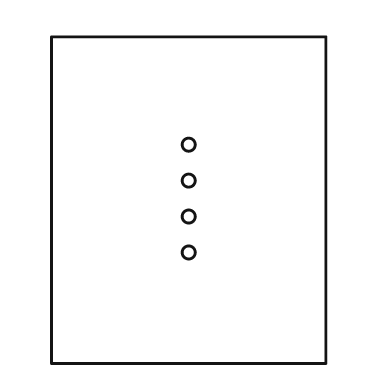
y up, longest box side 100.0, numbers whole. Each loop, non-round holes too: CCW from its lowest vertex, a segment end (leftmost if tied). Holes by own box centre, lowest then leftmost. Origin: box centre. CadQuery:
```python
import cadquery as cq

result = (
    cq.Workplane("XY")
    .moveTo(-42.0, -50.0)
    .lineTo(42.0, -50.0)
    .lineTo(42.0, 50.0)
    .lineTo(-42.0, 50.0)
    .close()
    .moveTo(0.0, -16.0)
    .circle(2.0)
    .moveTo(0.0, -5.0)
    .circle(2.0)
    .moveTo(0.0, 6.0)
    .circle(2.0)
    .moveTo(0.0, 17.0)
    .circle(2.0)
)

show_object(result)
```